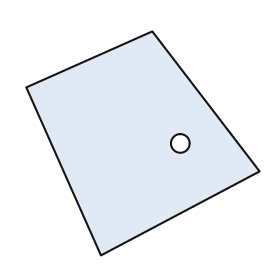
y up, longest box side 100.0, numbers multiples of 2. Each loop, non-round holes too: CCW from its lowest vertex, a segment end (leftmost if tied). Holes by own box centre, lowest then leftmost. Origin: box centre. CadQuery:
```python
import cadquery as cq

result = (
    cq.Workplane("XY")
    .moveTo(-18.0, -48.0)
    .lineTo(50.0, -12.0)
    .lineTo(4.0, 48.0)
    .lineTo(-50.0, 24.0)
    .close()
    .moveTo(16.0, 0.0)
    .circle(4.0)
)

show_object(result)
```